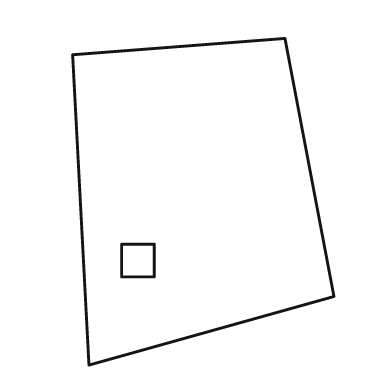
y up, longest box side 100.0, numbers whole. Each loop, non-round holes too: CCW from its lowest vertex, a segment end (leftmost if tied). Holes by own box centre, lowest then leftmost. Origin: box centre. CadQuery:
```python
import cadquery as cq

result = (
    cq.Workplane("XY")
    .moveTo(-35.0, -50.0)
    .lineTo(40.0, -29.0)
    .lineTo(25.0, 50.0)
    .lineTo(-40.0, 45.0)
    .close()
    .moveTo(-25.0, -23.0)
    .lineTo(-15.0, -23.0)
    .lineTo(-15.0, -13.0)
    .lineTo(-25.0, -13.0)
    .close()
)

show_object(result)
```